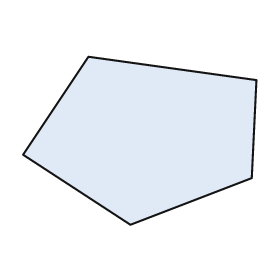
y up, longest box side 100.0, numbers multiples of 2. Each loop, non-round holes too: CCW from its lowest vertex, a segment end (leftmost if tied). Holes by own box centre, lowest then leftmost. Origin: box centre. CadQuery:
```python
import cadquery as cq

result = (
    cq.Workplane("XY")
    .moveTo(-4.0, -36.0)
    .lineTo(48.0, -16.0)
    .lineTo(50.0, 26.0)
    .lineTo(-22.0, 36.0)
    .lineTo(-50.0, -6.0)
    .close()
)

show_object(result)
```